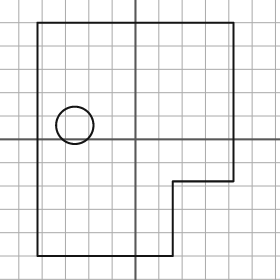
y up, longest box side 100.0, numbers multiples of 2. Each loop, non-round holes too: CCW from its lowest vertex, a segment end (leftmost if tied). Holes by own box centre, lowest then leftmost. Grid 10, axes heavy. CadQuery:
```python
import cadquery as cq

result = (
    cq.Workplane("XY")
    .moveTo(-42.0, -50.0)
    .lineTo(16.0, -50.0)
    .lineTo(16.0, -18.0)
    .lineTo(42.0, -18.0)
    .lineTo(42.0, 50.0)
    .lineTo(-42.0, 50.0)
    .close()
    .moveTo(-26.0, 6.0)
    .circle(8.0)
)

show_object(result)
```